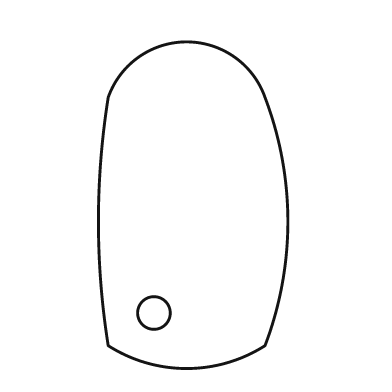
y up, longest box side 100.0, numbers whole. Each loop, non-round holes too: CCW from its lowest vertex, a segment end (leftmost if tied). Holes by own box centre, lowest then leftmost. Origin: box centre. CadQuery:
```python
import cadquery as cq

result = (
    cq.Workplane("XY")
    .moveTo(-26.0, -43.0)
    .threePointArc((-2.0, -50.0), (22.0, -43.0))
    .threePointArc((29.0, -5.0), (22.0, 33.0))
    .threePointArc((-2.0, 50.0), (-26.0, 33.0))
    .threePointArc((-29.0, -5.0), (-26.0, -43.0))
    .close()
    .moveTo(-12.0, -33.0)
    .circle(5.0)
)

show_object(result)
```